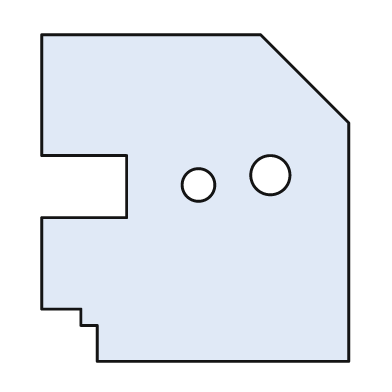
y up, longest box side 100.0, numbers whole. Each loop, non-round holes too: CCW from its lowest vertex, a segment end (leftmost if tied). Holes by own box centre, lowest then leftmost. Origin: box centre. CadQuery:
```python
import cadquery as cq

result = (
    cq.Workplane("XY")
    .moveTo(-30.0, -50.0)
    .lineTo(47.0, -50.0)
    .lineTo(47.0, 23.0)
    .lineTo(20.0, 50.0)
    .lineTo(-47.0, 50.0)
    .lineTo(-47.0, 13.0)
    .lineTo(-21.0, 13.0)
    .lineTo(-21.0, -6.0)
    .lineTo(-47.0, -6.0)
    .lineTo(-47.0, -34.0)
    .lineTo(-35.0, -34.0)
    .lineTo(-35.0, -39.0)
    .lineTo(-30.0, -39.0)
    .close()
    .moveTo(1.0, 4.0)
    .circle(5.0)
    .moveTo(23.0, 7.0)
    .circle(6.0)
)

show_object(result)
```